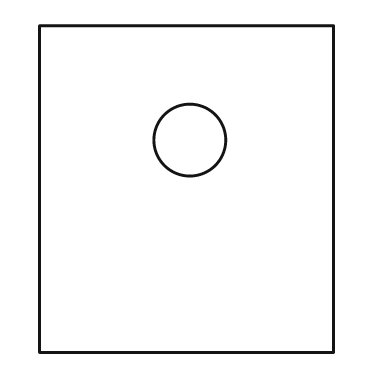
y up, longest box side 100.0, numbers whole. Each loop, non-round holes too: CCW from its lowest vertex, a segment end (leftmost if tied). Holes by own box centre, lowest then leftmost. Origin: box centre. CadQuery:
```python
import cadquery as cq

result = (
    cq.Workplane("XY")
    .moveTo(-45.0, -50.0)
    .lineTo(45.0, -50.0)
    .lineTo(45.0, 50.0)
    .lineTo(-45.0, 50.0)
    .close()
    .moveTo(1.0, 15.0)
    .circle(11.0)
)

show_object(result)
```